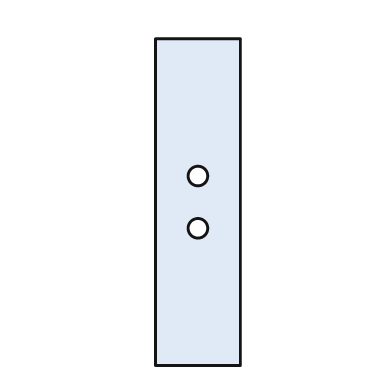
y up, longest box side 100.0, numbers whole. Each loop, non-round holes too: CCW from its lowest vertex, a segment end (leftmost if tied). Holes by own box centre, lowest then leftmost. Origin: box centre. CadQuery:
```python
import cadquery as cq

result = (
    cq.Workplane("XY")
    .moveTo(-13.0, -50.0)
    .lineTo(13.0, -50.0)
    .lineTo(13.0, 50.0)
    .lineTo(-13.0, 50.0)
    .close()
    .moveTo(0.0, -8.0)
    .circle(3.0)
    .moveTo(0.0, 8.0)
    .circle(3.0)
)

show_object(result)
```